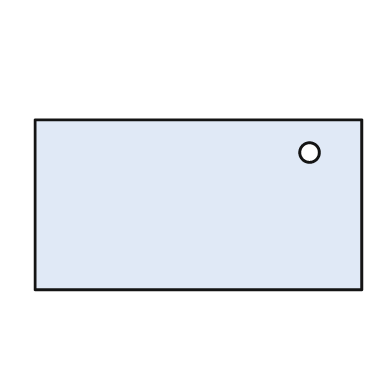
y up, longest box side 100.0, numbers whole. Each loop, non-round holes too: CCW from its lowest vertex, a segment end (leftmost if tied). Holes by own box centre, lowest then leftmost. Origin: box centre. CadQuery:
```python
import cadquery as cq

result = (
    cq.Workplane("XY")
    .moveTo(-50.0, -26.0)
    .lineTo(50.0, -26.0)
    .lineTo(50.0, 26.0)
    .lineTo(-50.0, 26.0)
    .close()
    .moveTo(34.0, 16.0)
    .circle(3.0)
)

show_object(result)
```